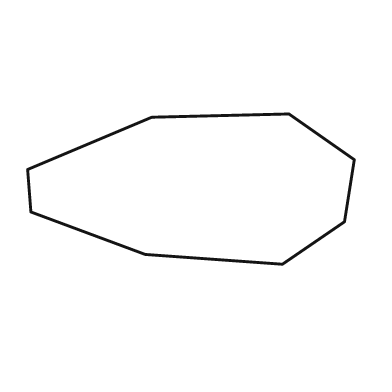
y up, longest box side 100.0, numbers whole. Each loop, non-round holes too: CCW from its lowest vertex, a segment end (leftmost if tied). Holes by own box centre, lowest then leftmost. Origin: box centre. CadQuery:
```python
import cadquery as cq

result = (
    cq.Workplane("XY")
    .moveTo(28.0, -23.0)
    .lineTo(47.0, -10.0)
    .lineTo(50.0, 9.0)
    .lineTo(30.0, 23.0)
    .lineTo(-12.0, 22.0)
    .lineTo(-50.0, 6.0)
    .lineTo(-49.0, -7.0)
    .lineTo(-14.0, -20.0)
    .close()
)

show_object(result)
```